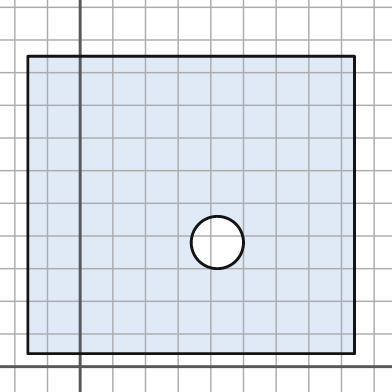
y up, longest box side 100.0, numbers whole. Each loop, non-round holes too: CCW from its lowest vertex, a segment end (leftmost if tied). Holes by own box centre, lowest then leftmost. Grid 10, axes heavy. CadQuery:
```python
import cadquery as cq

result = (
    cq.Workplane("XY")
    .moveTo(-16.0, 4.0)
    .lineTo(84.0, 4.0)
    .lineTo(84.0, 95.0)
    .lineTo(-16.0, 95.0)
    .close()
    .moveTo(42.0, 38.0)
    .circle(8.0)
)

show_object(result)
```